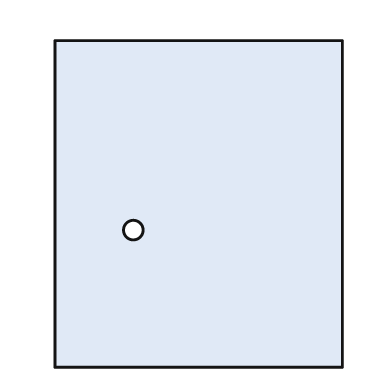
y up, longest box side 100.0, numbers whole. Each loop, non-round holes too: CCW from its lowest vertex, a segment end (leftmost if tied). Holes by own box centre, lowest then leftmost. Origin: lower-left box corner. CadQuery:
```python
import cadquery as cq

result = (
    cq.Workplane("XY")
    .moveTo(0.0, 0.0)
    .lineTo(88.0, 0.0)
    .lineTo(88.0, 100.0)
    .lineTo(0.0, 100.0)
    .close()
    .moveTo(24.0, 42.0)
    .circle(3.0)
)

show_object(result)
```